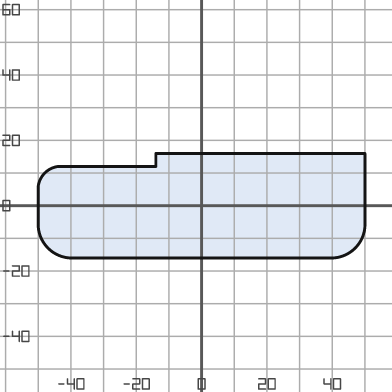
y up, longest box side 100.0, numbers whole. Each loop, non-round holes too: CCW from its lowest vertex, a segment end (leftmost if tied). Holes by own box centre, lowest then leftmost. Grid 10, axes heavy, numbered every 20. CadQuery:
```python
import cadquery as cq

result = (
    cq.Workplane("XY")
    .moveTo(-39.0, -16.0)
    .lineTo(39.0, -16.0)
    .threePointArc((47.0, -13.0), (50.0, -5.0))
    .lineTo(50.0, 16.0)
    .lineTo(-14.0, 16.0)
    .lineTo(-14.0, 12.0)
    .lineTo(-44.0, 12.0)
    .threePointArc((-48.0, 10.0), (-50.0, 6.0))
    .lineTo(-50.0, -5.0)
    .threePointArc((-47.0, -13.0), (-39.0, -16.0))
    .close()
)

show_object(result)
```